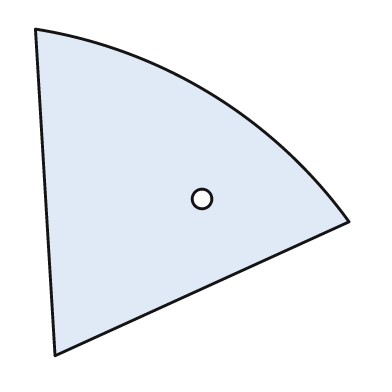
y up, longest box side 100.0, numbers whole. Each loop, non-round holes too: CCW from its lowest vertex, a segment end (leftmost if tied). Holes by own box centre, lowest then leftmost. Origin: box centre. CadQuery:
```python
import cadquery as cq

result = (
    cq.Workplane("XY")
    .moveTo(-42.0, -50.0)
    .lineTo(48.0, -9.0)
    .threePointArc((6.0, 30.0), (-48.0, 50.0))
    .close()
    .moveTo(3.0, -2.0)
    .circle(3.0)
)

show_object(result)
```